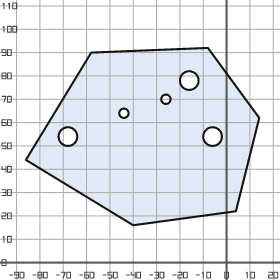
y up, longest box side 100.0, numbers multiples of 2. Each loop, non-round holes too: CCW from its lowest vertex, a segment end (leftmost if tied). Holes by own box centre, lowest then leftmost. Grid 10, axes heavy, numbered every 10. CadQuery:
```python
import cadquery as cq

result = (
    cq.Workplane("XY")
    .moveTo(-40.0, 16.0)
    .lineTo(4.0, 22.0)
    .lineTo(14.0, 62.0)
    .lineTo(-8.0, 92.0)
    .lineTo(-58.0, 90.0)
    .lineTo(-86.0, 44.0)
    .close()
    .moveTo(-68.0, 54.0)
    .circle(4.0)
    .moveTo(-6.0, 54.0)
    .circle(4.0)
    .moveTo(-44.0, 64.0)
    .circle(2.0)
    .moveTo(-26.0, 70.0)
    .circle(2.0)
    .moveTo(-16.0, 78.0)
    .circle(4.0)
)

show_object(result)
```